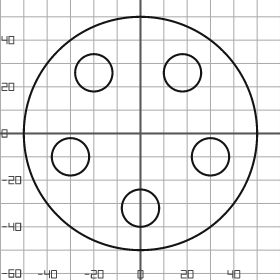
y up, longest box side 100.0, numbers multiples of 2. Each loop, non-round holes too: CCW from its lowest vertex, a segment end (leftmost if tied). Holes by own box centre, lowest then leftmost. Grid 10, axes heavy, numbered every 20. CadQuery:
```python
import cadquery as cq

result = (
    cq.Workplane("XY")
    .moveTo(0.0, 0.0)
    .circle(50.0)
    .moveTo(0.0, -32.0)
    .circle(8.0)
    .moveTo(-30.0, -10.0)
    .circle(8.0)
    .moveTo(30.0, -10.0)
    .circle(8.0)
    .moveTo(-20.0, 26.0)
    .circle(8.0)
    .moveTo(18.0, 26.0)
    .circle(8.0)
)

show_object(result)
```